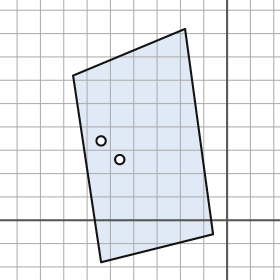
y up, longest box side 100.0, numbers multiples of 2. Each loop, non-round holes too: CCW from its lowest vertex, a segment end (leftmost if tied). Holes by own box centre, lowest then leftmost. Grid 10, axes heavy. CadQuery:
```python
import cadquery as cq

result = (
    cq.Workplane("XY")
    .moveTo(-54.0, -18.0)
    .lineTo(-6.0, -6.0)
    .lineTo(-18.0, 82.0)
    .lineTo(-66.0, 62.0)
    .close()
    .moveTo(-46.0, 26.0)
    .circle(2.0)
    .moveTo(-54.0, 34.0)
    .circle(2.0)
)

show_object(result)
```